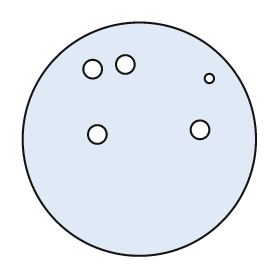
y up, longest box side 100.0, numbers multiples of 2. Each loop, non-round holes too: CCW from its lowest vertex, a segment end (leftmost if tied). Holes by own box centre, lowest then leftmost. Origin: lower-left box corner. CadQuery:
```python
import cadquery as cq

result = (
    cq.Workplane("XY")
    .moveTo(50.0, 50.0)
    .circle(50.0)
    .moveTo(32.0, 52.0)
    .circle(4.0)
    .moveTo(76.0, 54.0)
    .circle(4.0)
    .moveTo(80.0, 76.0)
    .circle(2.0)
    .moveTo(30.0, 80.0)
    .circle(4.0)
    .moveTo(44.0, 82.0)
    .circle(4.0)
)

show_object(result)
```